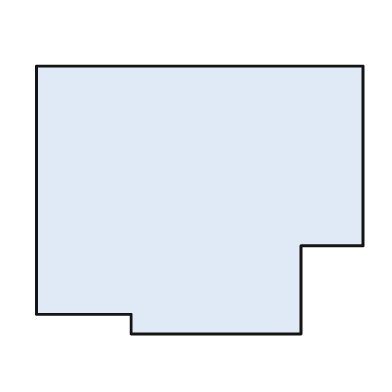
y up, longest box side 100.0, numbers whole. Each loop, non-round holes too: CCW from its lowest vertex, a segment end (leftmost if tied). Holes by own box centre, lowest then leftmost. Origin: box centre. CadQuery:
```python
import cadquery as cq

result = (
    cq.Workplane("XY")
    .moveTo(-21.0, -41.0)
    .lineTo(31.0, -41.0)
    .lineTo(31.0, -14.0)
    .lineTo(50.0, -14.0)
    .lineTo(50.0, 41.0)
    .lineTo(-50.0, 41.0)
    .lineTo(-50.0, -35.0)
    .lineTo(-21.0, -35.0)
    .close()
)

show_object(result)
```